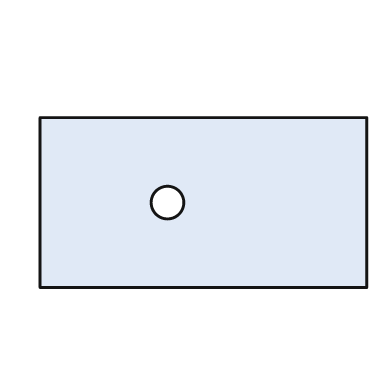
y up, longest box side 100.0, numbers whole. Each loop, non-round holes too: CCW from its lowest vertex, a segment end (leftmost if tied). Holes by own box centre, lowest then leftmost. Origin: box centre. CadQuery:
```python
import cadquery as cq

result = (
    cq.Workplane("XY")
    .moveTo(-50.0, -26.0)
    .lineTo(50.0, -26.0)
    .lineTo(50.0, 26.0)
    .lineTo(-50.0, 26.0)
    .close()
    .moveTo(-11.0, 0.0)
    .circle(5.0)
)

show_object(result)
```